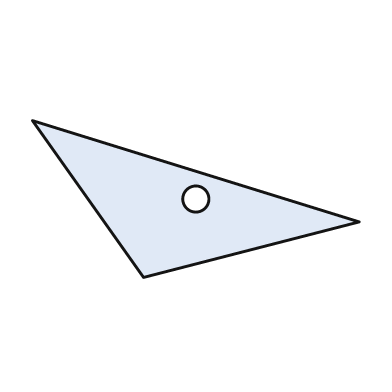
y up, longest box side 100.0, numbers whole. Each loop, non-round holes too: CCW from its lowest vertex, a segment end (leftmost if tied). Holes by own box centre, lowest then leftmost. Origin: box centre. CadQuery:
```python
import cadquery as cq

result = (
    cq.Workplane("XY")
    .moveTo(-16.0, -24.0)
    .lineTo(50.0, -7.0)
    .lineTo(-50.0, 24.0)
    .close()
    .moveTo(0.0, 0.0)
    .circle(4.0)
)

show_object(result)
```